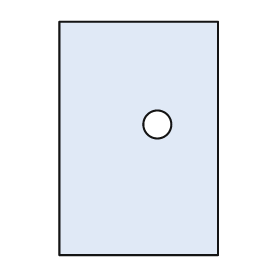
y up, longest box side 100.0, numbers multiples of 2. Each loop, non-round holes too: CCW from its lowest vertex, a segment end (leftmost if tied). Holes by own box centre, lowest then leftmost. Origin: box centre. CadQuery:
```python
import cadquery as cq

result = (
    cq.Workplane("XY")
    .moveTo(-34.0, -50.0)
    .lineTo(34.0, -50.0)
    .lineTo(34.0, 50.0)
    .lineTo(-34.0, 50.0)
    .close()
    .moveTo(8.0, 6.0)
    .circle(6.0)
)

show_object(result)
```